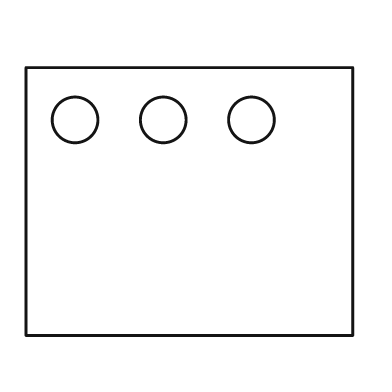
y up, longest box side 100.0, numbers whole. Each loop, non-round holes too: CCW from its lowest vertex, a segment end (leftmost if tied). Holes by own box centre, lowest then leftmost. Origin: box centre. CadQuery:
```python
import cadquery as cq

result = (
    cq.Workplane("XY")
    .moveTo(-50.0, -41.0)
    .lineTo(50.0, -41.0)
    .lineTo(50.0, 41.0)
    .lineTo(-50.0, 41.0)
    .close()
    .moveTo(-35.0, 25.0)
    .circle(7.0)
    .moveTo(-8.0, 25.0)
    .circle(7.0)
    .moveTo(19.0, 25.0)
    .circle(7.0)
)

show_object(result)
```